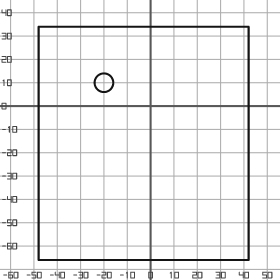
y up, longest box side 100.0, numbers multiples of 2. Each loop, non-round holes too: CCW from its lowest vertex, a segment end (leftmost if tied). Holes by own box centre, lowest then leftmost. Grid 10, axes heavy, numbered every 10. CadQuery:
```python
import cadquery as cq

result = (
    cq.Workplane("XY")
    .moveTo(-48.0, -66.0)
    .lineTo(42.0, -66.0)
    .lineTo(42.0, 34.0)
    .lineTo(-48.0, 34.0)
    .close()
    .moveTo(-20.0, 10.0)
    .circle(4.0)
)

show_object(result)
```